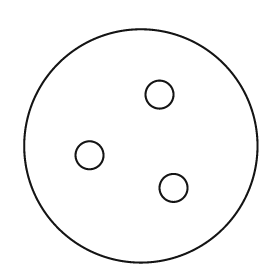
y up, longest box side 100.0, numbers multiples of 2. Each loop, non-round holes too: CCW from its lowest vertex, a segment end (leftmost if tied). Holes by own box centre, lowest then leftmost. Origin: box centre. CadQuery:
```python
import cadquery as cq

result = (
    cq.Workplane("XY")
    .moveTo(0.0, 0.0)
    .circle(50.0)
    .moveTo(14.0, -18.0)
    .circle(6.0)
    .moveTo(-22.0, -4.0)
    .circle(6.0)
    .moveTo(8.0, 22.0)
    .circle(6.0)
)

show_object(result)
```